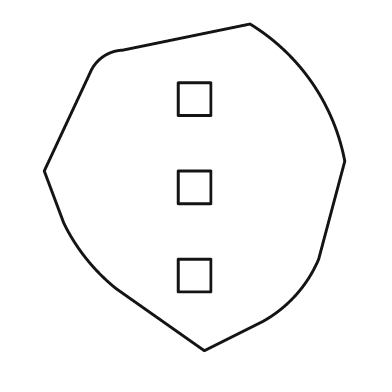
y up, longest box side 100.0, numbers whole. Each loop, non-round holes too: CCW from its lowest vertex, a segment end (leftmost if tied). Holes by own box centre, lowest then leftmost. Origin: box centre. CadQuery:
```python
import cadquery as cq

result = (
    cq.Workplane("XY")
    .moveTo(3.0, -50.0)
    .lineTo(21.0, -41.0)
    .threePointArc((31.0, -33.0), (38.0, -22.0))
    .lineTo(46.0, 8.0)
    .threePointArc((36.0, 32.0), (17.0, 50.0))
    .lineTo(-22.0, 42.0)
    .threePointArc((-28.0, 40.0), (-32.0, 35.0))
    .lineTo(-46.0, 5.0)
    .lineTo(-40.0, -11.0)
    .threePointArc((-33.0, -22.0), (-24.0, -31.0))
    .close()
    .moveTo(-5.0, -32.0)
    .lineTo(5.0, -32.0)
    .lineTo(5.0, -22.0)
    .lineTo(-5.0, -22.0)
    .close()
    .moveTo(-5.0, -5.0)
    .lineTo(5.0, -5.0)
    .lineTo(5.0, 5.0)
    .lineTo(-5.0, 5.0)
    .close()
    .moveTo(-5.0, 22.0)
    .lineTo(5.0, 22.0)
    .lineTo(5.0, 32.0)
    .lineTo(-5.0, 32.0)
    .close()
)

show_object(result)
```